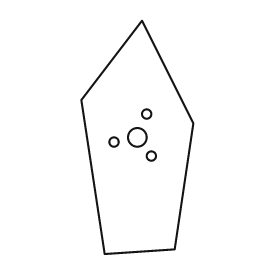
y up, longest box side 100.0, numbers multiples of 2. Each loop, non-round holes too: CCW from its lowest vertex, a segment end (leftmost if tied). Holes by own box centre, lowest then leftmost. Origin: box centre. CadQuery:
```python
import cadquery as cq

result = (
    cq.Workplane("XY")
    .moveTo(-14.0, -50.0)
    .lineTo(16.0, -48.0)
    .lineTo(24.0, 6.0)
    .lineTo(2.0, 50.0)
    .lineTo(-24.0, 16.0)
    .close()
    .moveTo(6.0, -8.0)
    .circle(2.0)
    .moveTo(-10.0, -2.0)
    .circle(2.0)
    .moveTo(0.0, 0.0)
    .circle(4.0)
    .moveTo(4.0, 10.0)
    .circle(2.0)
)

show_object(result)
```